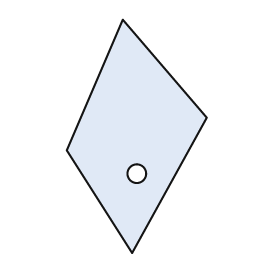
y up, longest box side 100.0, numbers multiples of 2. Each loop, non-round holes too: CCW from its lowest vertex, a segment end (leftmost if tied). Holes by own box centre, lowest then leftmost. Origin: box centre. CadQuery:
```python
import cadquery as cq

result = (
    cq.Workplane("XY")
    .moveTo(-2.0, -50.0)
    .lineTo(30.0, 8.0)
    .lineTo(-6.0, 50.0)
    .lineTo(-30.0, -6.0)
    .close()
    .moveTo(0.0, -16.0)
    .circle(4.0)
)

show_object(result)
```